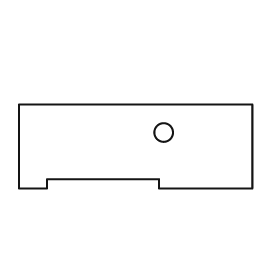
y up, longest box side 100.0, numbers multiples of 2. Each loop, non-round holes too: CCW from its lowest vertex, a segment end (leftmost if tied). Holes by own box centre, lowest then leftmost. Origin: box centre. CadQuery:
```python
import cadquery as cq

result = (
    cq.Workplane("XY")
    .moveTo(-50.0, -18.0)
    .lineTo(-38.0, -18.0)
    .lineTo(-38.0, -14.0)
    .lineTo(10.0, -14.0)
    .lineTo(10.0, -18.0)
    .lineTo(50.0, -18.0)
    .lineTo(50.0, 18.0)
    .lineTo(-50.0, 18.0)
    .close()
    .moveTo(12.0, 6.0)
    .circle(4.0)
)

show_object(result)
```